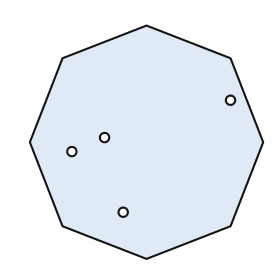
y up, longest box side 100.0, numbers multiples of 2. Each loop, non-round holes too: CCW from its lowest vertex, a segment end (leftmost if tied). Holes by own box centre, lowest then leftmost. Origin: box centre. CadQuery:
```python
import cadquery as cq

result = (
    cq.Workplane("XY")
    .moveTo(0.0, -50.0)
    .lineTo(36.0, -36.0)
    .lineTo(50.0, 0.0)
    .lineTo(36.0, 36.0)
    .lineTo(0.0, 50.0)
    .lineTo(-36.0, 36.0)
    .lineTo(-50.0, 0.0)
    .lineTo(-36.0, -36.0)
    .close()
    .moveTo(-10.0, -30.0)
    .circle(2.0)
    .moveTo(-32.0, -4.0)
    .circle(2.0)
    .moveTo(-18.0, 2.0)
    .circle(2.0)
    .moveTo(36.0, 18.0)
    .circle(2.0)
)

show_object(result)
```